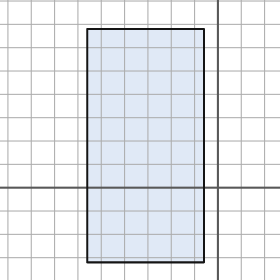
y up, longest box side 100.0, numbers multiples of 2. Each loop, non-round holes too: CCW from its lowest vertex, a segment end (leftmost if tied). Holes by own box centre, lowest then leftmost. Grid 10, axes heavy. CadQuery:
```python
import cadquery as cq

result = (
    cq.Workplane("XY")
    .moveTo(-56.0, -32.0)
    .lineTo(-6.0, -32.0)
    .lineTo(-6.0, 68.0)
    .lineTo(-56.0, 68.0)
    .close()
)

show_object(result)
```